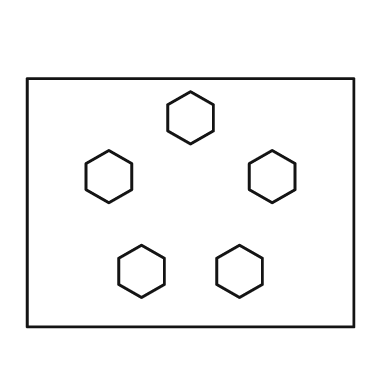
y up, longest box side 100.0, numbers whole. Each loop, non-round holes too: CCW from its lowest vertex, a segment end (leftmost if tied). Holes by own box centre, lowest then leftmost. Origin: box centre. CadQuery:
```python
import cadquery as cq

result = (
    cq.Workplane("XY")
    .moveTo(-50.0, -38.0)
    .lineTo(50.0, -38.0)
    .lineTo(50.0, 38.0)
    .lineTo(-50.0, 38.0)
    .close()
    .moveTo(-15.0, -29.0)
    .lineTo(-8.0, -25.0)
    .lineTo(-8.0, -17.0)
    .lineTo(-15.0, -13.0)
    .lineTo(-22.0, -17.0)
    .lineTo(-22.0, -25.0)
    .close()
    .moveTo(15.0, -29.0)
    .lineTo(22.0, -25.0)
    .lineTo(22.0, -17.0)
    .lineTo(15.0, -13.0)
    .lineTo(8.0, -17.0)
    .lineTo(8.0, -25.0)
    .close()
    .moveTo(-25.0, 0.0)
    .lineTo(-18.0, 4.0)
    .lineTo(-18.0, 12.0)
    .lineTo(-25.0, 16.0)
    .lineTo(-32.0, 12.0)
    .lineTo(-32.0, 4.0)
    .close()
    .moveTo(25.0, 0.0)
    .lineTo(32.0, 4.0)
    .lineTo(32.0, 12.0)
    .lineTo(25.0, 16.0)
    .lineTo(18.0, 12.0)
    .lineTo(18.0, 4.0)
    .close()
    .moveTo(0.0, 18.0)
    .lineTo(7.0, 22.0)
    .lineTo(7.0, 30.0)
    .lineTo(0.0, 34.0)
    .lineTo(-7.0, 30.0)
    .lineTo(-7.0, 22.0)
    .close()
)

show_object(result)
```